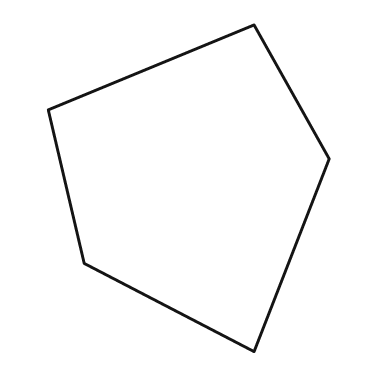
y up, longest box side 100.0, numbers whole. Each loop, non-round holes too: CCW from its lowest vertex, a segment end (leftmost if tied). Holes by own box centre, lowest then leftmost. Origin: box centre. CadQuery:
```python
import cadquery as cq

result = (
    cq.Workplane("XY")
    .moveTo(20.0, -50.0)
    .lineTo(43.0, 9.0)
    .lineTo(20.0, 50.0)
    .lineTo(-43.0, 24.0)
    .lineTo(-32.0, -23.0)
    .close()
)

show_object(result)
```